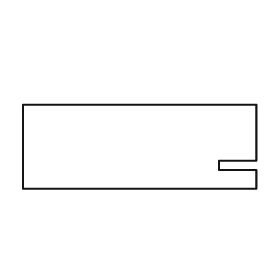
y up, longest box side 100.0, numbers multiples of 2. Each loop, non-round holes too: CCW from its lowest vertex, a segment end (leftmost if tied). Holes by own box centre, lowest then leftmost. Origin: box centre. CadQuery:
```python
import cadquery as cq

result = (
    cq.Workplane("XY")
    .moveTo(-50.0, -18.0)
    .lineTo(50.0, -18.0)
    .lineTo(50.0, -10.0)
    .lineTo(34.0, -10.0)
    .lineTo(34.0, -6.0)
    .lineTo(50.0, -6.0)
    .lineTo(50.0, 18.0)
    .lineTo(-50.0, 18.0)
    .close()
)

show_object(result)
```